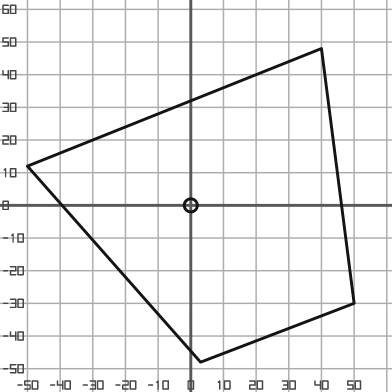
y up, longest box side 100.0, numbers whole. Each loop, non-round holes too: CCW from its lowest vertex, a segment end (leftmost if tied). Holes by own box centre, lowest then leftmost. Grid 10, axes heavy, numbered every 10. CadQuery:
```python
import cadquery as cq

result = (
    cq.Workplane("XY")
    .moveTo(3.0, -48.0)
    .lineTo(50.0, -30.0)
    .lineTo(40.0, 48.0)
    .lineTo(-50.0, 12.0)
    .close()
    .moveTo(0.0, 0.0)
    .circle(2.0)
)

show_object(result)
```